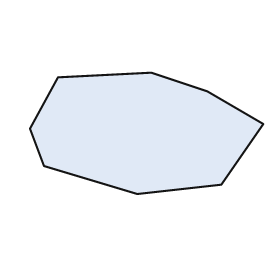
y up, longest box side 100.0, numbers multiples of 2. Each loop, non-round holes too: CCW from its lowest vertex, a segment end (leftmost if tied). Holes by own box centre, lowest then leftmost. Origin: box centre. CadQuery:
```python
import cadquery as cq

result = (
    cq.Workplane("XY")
    .moveTo(-4.0, -26.0)
    .lineTo(32.0, -22.0)
    .lineTo(50.0, 4.0)
    .lineTo(26.0, 18.0)
    .lineTo(2.0, 26.0)
    .lineTo(-38.0, 24.0)
    .lineTo(-50.0, 2.0)
    .lineTo(-44.0, -14.0)
    .close()
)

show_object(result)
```